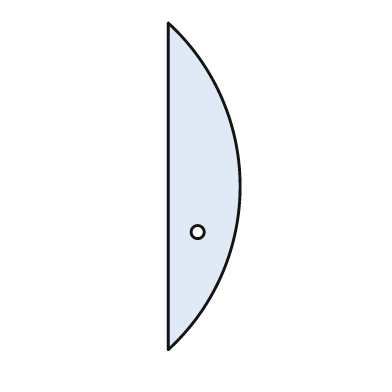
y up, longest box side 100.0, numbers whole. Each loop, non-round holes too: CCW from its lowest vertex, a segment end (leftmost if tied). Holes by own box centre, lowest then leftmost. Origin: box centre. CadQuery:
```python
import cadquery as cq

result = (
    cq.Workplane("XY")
    .moveTo(-11.0, -50.0)
    .threePointArc((11.0, 0.0), (-11.0, 50.0))
    .close()
    .moveTo(-2.0, -14.0)
    .circle(2.0)
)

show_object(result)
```